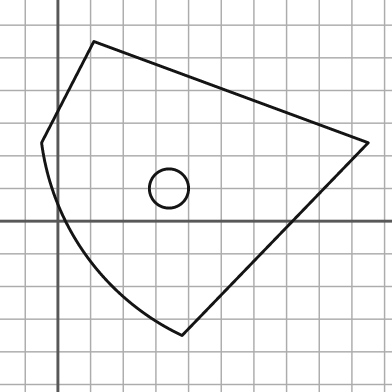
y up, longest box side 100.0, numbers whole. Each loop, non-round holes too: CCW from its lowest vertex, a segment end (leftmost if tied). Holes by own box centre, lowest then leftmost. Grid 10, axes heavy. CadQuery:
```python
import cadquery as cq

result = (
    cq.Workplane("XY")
    .moveTo(38.0, -35.0)
    .lineTo(95.0, 24.0)
    .lineTo(11.0, 55.0)
    .lineTo(-5.0, 24.0)
    .threePointArc((9.0, -11.0), (38.0, -35.0))
    .close()
    .moveTo(34.0, 10.0)
    .circle(6.0)
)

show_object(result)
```